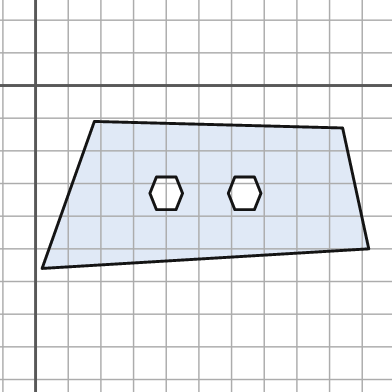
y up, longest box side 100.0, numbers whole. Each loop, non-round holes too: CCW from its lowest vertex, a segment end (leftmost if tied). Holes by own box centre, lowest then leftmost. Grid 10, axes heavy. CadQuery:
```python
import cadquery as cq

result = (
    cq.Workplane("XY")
    .moveTo(2.0, -56.0)
    .lineTo(102.0, -50.0)
    .lineTo(94.0, -13.0)
    .lineTo(18.0, -11.0)
    .close()
    .moveTo(37.0, -38.0)
    .lineTo(43.0, -38.0)
    .lineTo(45.0, -33.0)
    .lineTo(43.0, -28.0)
    .lineTo(37.0, -28.0)
    .lineTo(35.0, -33.0)
    .close()
    .moveTo(61.0, -38.0)
    .lineTo(67.0, -38.0)
    .lineTo(69.0, -33.0)
    .lineTo(67.0, -28.0)
    .lineTo(61.0, -28.0)
    .lineTo(59.0, -33.0)
    .close()
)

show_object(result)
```